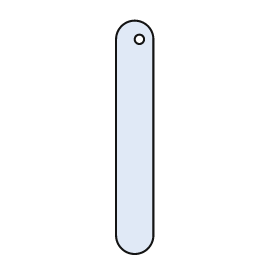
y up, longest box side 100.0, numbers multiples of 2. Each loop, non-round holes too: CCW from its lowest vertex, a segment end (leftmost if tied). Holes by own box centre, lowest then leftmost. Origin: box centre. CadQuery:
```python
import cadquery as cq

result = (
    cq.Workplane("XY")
    .moveTo(-8.0, -42.0)
    .threePointArc((0.0, -50.0), (8.0, -42.0))
    .lineTo(8.0, 42.0)
    .threePointArc((0.0, 50.0), (-8.0, 42.0))
    .close()
    .moveTo(2.0, 42.0)
    .circle(2.0)
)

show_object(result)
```